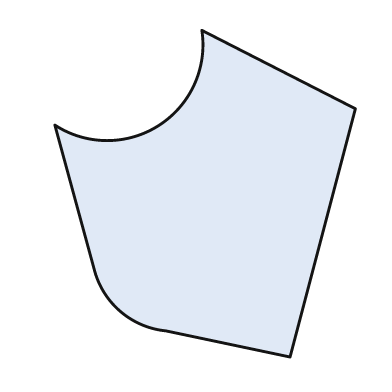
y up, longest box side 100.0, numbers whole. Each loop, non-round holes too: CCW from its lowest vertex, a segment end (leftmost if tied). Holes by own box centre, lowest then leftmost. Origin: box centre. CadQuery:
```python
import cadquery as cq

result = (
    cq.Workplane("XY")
    .moveTo(26.0, -50.0)
    .lineTo(46.0, 26.0)
    .lineTo(-1.0, 50.0)
    .threePointArc((-14.0, 21.0), (-46.0, 21.0))
    .lineTo(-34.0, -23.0)
    .threePointArc((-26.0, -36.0), (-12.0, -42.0))
    .close()
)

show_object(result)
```